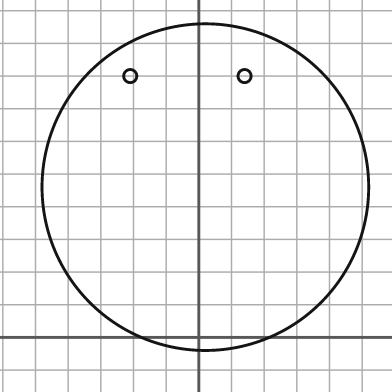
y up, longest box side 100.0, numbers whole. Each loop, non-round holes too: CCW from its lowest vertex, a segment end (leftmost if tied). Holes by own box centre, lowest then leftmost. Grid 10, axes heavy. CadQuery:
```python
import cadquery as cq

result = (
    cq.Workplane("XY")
    .moveTo(2.0, 46.0)
    .circle(50.0)
    .moveTo(-21.0, 80.0)
    .circle(2.0)
    .moveTo(14.0, 80.0)
    .circle(2.0)
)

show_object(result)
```